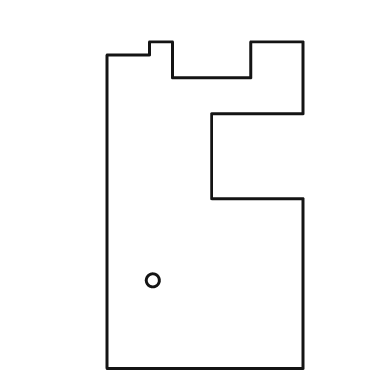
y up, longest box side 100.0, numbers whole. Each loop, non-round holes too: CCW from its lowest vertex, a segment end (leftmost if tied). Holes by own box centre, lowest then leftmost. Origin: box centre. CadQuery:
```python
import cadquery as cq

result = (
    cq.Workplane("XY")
    .moveTo(-30.0, -50.0)
    .lineTo(30.0, -50.0)
    .lineTo(30.0, 2.0)
    .lineTo(2.0, 2.0)
    .lineTo(2.0, 28.0)
    .lineTo(30.0, 28.0)
    .lineTo(30.0, 50.0)
    .lineTo(14.0, 50.0)
    .lineTo(14.0, 39.0)
    .lineTo(-10.0, 39.0)
    .lineTo(-10.0, 50.0)
    .lineTo(-17.0, 50.0)
    .lineTo(-17.0, 46.0)
    .lineTo(-30.0, 46.0)
    .close()
    .moveTo(-16.0, -23.0)
    .circle(2.0)
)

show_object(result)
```